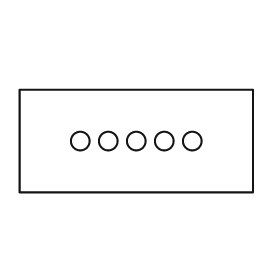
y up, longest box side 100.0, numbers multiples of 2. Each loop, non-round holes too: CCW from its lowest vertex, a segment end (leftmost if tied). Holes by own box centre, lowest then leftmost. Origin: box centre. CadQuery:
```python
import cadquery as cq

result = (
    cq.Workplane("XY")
    .moveTo(-50.0, -22.0)
    .lineTo(50.0, -22.0)
    .lineTo(50.0, 22.0)
    .lineTo(-50.0, 22.0)
    .close()
    .moveTo(-24.0, 0.0)
    .circle(4.0)
    .moveTo(-12.0, 0.0)
    .circle(4.0)
    .moveTo(0.0, 0.0)
    .circle(4.0)
    .moveTo(12.0, 0.0)
    .circle(4.0)
    .moveTo(24.0, 0.0)
    .circle(4.0)
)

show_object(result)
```